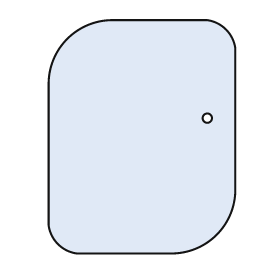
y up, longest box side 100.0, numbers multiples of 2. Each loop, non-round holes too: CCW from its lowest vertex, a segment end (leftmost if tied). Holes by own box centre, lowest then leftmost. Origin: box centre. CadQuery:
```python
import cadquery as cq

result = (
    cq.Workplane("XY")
    .moveTo(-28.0, -50.0)
    .lineTo(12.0, -50.0)
    .threePointArc((32.0, -42.0), (40.0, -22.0))
    .lineTo(40.0, 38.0)
    .threePointArc((36.0, 46.0), (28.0, 50.0))
    .lineTo(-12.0, 50.0)
    .threePointArc((-32.0, 42.0), (-40.0, 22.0))
    .lineTo(-40.0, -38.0)
    .threePointArc((-36.0, -46.0), (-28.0, -50.0))
    .close()
    .moveTo(28.0, 8.0)
    .circle(2.0)
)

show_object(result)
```